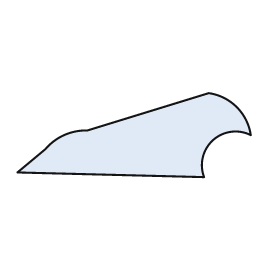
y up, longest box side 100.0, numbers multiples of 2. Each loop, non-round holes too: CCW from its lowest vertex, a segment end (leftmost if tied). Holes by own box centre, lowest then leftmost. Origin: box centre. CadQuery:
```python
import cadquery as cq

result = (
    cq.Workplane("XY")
    .moveTo(30.0, -18.0)
    .threePointArc((34.0, -2.0), (50.0, 0.0))
    .threePointArc((44.0, 12.0), (32.0, 18.0))
    .lineTo(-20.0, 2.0)
    .threePointArc((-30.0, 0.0), (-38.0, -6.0))
    .lineTo(-50.0, -16.0)
    .close()
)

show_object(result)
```